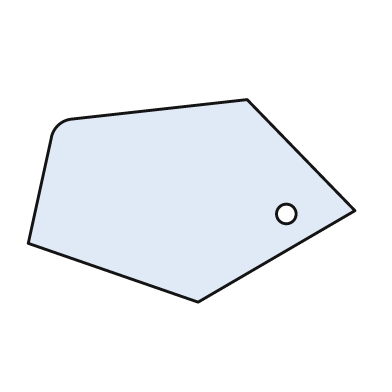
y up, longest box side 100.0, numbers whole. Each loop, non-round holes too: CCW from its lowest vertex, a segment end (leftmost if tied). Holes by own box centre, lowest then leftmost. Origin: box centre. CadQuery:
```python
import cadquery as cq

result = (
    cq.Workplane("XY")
    .moveTo(2.0, -31.0)
    .lineTo(50.0, -3.0)
    .lineTo(17.0, 31.0)
    .lineTo(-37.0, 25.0)
    .threePointArc((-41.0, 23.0), (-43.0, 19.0))
    .lineTo(-50.0, -13.0)
    .close()
    .moveTo(29.0, -4.0)
    .circle(3.0)
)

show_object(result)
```